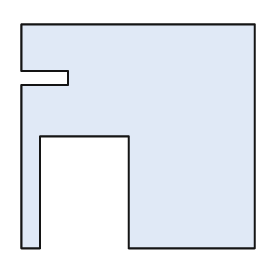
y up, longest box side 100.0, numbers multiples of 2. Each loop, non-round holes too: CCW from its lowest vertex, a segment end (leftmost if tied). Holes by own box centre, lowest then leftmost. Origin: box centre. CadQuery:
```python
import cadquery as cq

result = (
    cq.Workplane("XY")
    .moveTo(-50.0, -48.0)
    .lineTo(-42.0, -48.0)
    .lineTo(-42.0, 0.0)
    .lineTo(-4.0, 0.0)
    .lineTo(-4.0, -48.0)
    .lineTo(50.0, -48.0)
    .lineTo(50.0, 48.0)
    .lineTo(-50.0, 48.0)
    .lineTo(-50.0, 28.0)
    .lineTo(-30.0, 28.0)
    .lineTo(-30.0, 22.0)
    .lineTo(-50.0, 22.0)
    .close()
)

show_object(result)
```